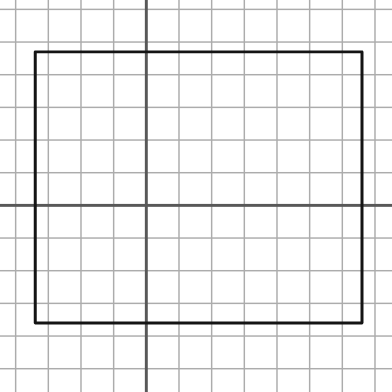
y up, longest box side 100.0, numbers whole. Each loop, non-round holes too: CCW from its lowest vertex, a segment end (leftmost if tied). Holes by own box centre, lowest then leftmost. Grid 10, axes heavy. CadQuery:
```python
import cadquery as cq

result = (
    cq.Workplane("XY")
    .moveTo(-34.0, -36.0)
    .lineTo(66.0, -36.0)
    .lineTo(66.0, 47.0)
    .lineTo(-34.0, 47.0)
    .close()
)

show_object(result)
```